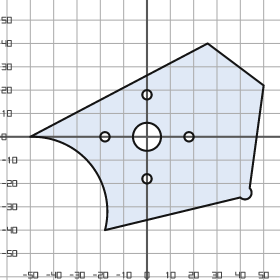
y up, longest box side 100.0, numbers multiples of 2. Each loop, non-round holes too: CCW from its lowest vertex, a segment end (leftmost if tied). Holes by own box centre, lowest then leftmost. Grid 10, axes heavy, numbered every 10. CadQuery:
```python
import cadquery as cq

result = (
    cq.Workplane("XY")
    .moveTo(-18.0, -40.0)
    .lineTo(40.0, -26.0)
    .threePointArc((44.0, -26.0), (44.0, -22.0))
    .lineTo(50.0, 22.0)
    .lineTo(26.0, 40.0)
    .lineTo(-50.0, 0.0)
    .threePointArc((-24.0, -12.0), (-18.0, -40.0))
    .close()
    .moveTo(0.0, -18.0)
    .circle(2.0)
    .moveTo(-18.0, 0.0)
    .circle(2.0)
    .moveTo(0.0, 0.0)
    .circle(6.0)
    .moveTo(18.0, 0.0)
    .circle(2.0)
    .moveTo(0.0, 18.0)
    .circle(2.0)
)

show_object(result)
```